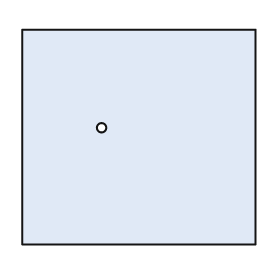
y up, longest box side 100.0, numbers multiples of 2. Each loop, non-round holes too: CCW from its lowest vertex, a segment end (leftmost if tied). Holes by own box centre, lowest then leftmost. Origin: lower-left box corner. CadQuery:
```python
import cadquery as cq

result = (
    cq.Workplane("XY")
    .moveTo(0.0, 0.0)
    .lineTo(100.0, 0.0)
    .lineTo(100.0, 92.0)
    .lineTo(0.0, 92.0)
    .close()
    .moveTo(34.0, 50.0)
    .circle(2.0)
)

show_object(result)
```